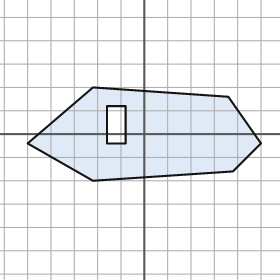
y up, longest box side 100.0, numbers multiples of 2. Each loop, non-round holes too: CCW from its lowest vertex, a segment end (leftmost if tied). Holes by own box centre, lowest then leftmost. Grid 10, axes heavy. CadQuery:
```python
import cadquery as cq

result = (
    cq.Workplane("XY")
    .moveTo(-22.0, -20.0)
    .lineTo(38.0, -16.0)
    .lineTo(50.0, -4.0)
    .lineTo(36.0, 16.0)
    .lineTo(-22.0, 20.0)
    .lineTo(-50.0, -4.0)
    .close()
    .moveTo(-16.0, -4.0)
    .lineTo(-8.0, -4.0)
    .lineTo(-8.0, 12.0)
    .lineTo(-16.0, 12.0)
    .close()
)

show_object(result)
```